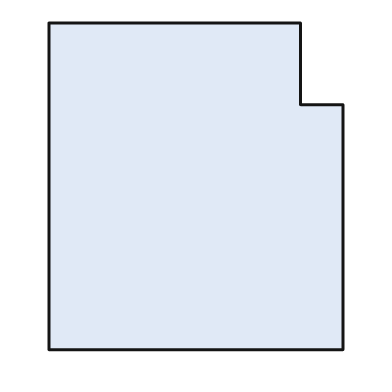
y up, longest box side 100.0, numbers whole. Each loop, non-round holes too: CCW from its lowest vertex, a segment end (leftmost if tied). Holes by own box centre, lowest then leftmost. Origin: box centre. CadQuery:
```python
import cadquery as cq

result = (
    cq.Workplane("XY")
    .moveTo(-45.0, -50.0)
    .lineTo(45.0, -50.0)
    .lineTo(45.0, 25.0)
    .lineTo(32.0, 25.0)
    .lineTo(32.0, 50.0)
    .lineTo(-45.0, 50.0)
    .close()
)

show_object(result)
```